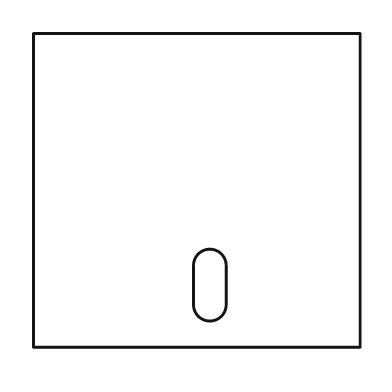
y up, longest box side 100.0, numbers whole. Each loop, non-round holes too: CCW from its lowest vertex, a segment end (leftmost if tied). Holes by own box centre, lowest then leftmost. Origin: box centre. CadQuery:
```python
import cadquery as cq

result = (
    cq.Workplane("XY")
    .moveTo(-50.0, -48.0)
    .lineTo(50.0, -48.0)
    .lineTo(50.0, 48.0)
    .lineTo(-50.0, 48.0)
    .close()
    .moveTo(-1.0, -35.0)
    .threePointArc((4.0, -40.0), (9.0, -35.0))
    .lineTo(9.0, -23.0)
    .threePointArc((4.0, -18.0), (-1.0, -23.0))
    .close()
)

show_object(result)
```